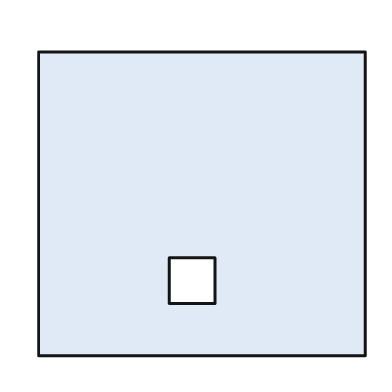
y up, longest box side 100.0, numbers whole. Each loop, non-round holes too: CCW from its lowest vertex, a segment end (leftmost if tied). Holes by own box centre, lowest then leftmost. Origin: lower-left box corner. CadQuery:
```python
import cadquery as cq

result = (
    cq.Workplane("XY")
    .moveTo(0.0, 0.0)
    .lineTo(100.0, 0.0)
    .lineTo(100.0, 93.0)
    .lineTo(0.0, 93.0)
    .close()
    .moveTo(40.0, 16.0)
    .lineTo(54.0, 16.0)
    .lineTo(54.0, 30.0)
    .lineTo(40.0, 30.0)
    .close()
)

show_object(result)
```